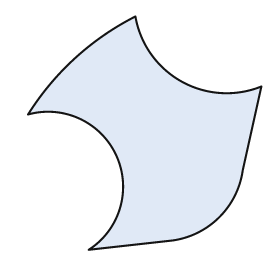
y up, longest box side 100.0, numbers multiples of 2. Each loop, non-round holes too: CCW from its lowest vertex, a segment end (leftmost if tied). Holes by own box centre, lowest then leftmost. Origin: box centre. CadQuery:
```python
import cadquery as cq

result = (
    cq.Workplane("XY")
    .moveTo(-24.0, -50.0)
    .lineTo(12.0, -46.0)
    .threePointArc((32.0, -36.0), (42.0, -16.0))
    .lineTo(50.0, 20.0)
    .threePointArc((16.0, 22.0), (-4.0, 50.0))
    .threePointArc((-30.0, 32.0), (-50.0, 8.0))
    .threePointArc((-12.0, -10.0), (-24.0, -50.0))
    .close()
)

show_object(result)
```